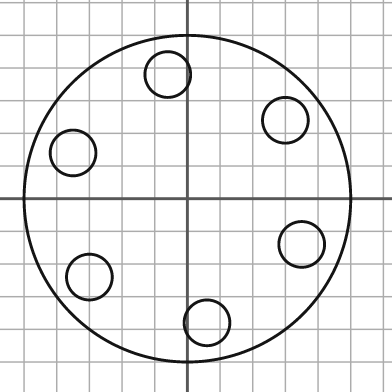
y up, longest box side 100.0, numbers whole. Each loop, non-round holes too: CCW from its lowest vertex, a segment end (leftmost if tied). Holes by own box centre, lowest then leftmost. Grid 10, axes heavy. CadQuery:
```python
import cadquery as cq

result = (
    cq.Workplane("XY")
    .moveTo(0.0, 0.0)
    .circle(50.0)
    .moveTo(6.0, -38.0)
    .circle(7.0)
    .moveTo(-30.0, -24.0)
    .circle(7.0)
    .moveTo(35.0, -14.0)
    .circle(7.0)
    .moveTo(-35.0, 14.0)
    .circle(7.0)
    .moveTo(30.0, 24.0)
    .circle(7.0)
    .moveTo(-6.0, 38.0)
    .circle(7.0)
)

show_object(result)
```